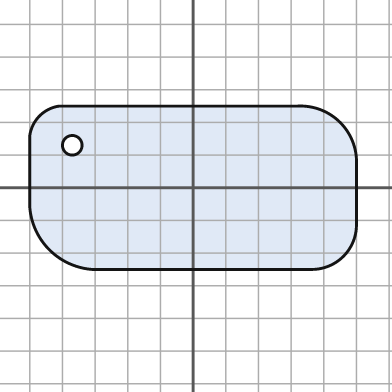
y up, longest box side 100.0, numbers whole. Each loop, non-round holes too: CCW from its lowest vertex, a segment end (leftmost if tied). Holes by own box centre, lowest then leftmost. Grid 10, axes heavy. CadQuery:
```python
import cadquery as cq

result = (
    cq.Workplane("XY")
    .moveTo(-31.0, -25.0)
    .lineTo(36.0, -25.0)
    .threePointArc((46.0, -21.0), (50.0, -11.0))
    .lineTo(50.0, 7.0)
    .threePointArc((45.0, 20.0), (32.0, 25.0))
    .lineTo(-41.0, 25.0)
    .threePointArc((-47.0, 22.0), (-50.0, 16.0))
    .lineTo(-50.0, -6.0)
    .threePointArc((-44.0, -19.0), (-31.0, -25.0))
    .close()
    .moveTo(-37.0, 13.0)
    .circle(3.0)
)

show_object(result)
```